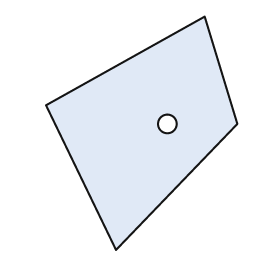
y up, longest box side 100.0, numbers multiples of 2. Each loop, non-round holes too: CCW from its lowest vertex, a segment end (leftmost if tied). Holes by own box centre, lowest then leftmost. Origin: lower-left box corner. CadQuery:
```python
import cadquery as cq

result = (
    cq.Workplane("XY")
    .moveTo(30.0, 0.0)
    .lineTo(82.0, 54.0)
    .lineTo(68.0, 100.0)
    .lineTo(0.0, 62.0)
    .close()
    .moveTo(52.0, 54.0)
    .circle(4.0)
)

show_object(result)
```